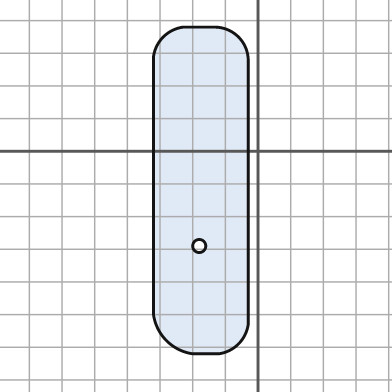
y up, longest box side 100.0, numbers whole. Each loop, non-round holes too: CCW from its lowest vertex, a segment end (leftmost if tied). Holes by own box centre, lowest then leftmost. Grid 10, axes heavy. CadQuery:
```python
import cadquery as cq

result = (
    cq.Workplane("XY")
    .moveTo(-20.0, -62.0)
    .lineTo(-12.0, -62.0)
    .threePointArc((-6.0, -59.0), (-3.0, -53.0))
    .lineTo(-3.0, 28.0)
    .threePointArc((-6.0, 35.0), (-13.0, 38.0))
    .lineTo(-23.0, 38.0)
    .threePointArc((-29.0, 35.0), (-32.0, 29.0))
    .lineTo(-32.0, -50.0)
    .threePointArc((-28.0, -58.0), (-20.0, -62.0))
    .close()
    .moveTo(-18.0, -29.0)
    .circle(2.0)
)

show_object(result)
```